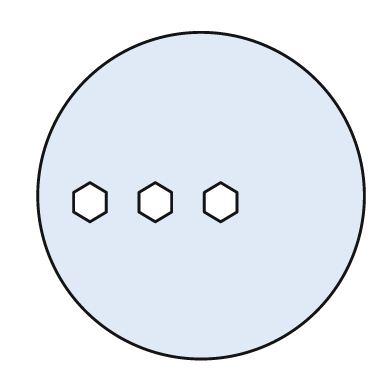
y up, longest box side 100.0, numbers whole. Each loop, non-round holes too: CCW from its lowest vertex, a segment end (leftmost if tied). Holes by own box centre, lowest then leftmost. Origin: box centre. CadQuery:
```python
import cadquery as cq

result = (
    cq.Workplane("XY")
    .moveTo(0.0, 0.0)
    .circle(50.0)
    .moveTo(-34.0, -8.0)
    .lineTo(-29.0, -5.0)
    .lineTo(-29.0, 1.0)
    .lineTo(-34.0, 4.0)
    .lineTo(-39.0, 1.0)
    .lineTo(-39.0, -5.0)
    .close()
    .moveTo(-14.0, -8.0)
    .lineTo(-9.0, -5.0)
    .lineTo(-9.0, 1.0)
    .lineTo(-14.0, 4.0)
    .lineTo(-19.0, 1.0)
    .lineTo(-19.0, -5.0)
    .close()
    .moveTo(6.0, -8.0)
    .lineTo(11.0, -5.0)
    .lineTo(11.0, 1.0)
    .lineTo(6.0, 4.0)
    .lineTo(1.0, 1.0)
    .lineTo(1.0, -5.0)
    .close()
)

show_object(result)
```